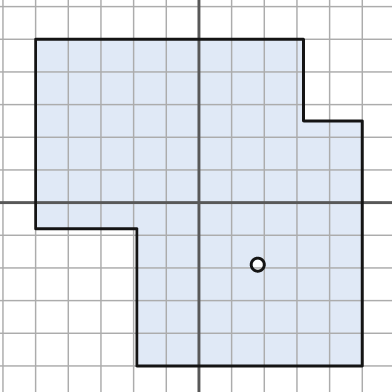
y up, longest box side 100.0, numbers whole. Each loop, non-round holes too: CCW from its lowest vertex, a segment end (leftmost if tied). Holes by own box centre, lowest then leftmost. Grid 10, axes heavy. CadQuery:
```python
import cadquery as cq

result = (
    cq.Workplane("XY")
    .moveTo(-19.0, -50.0)
    .lineTo(50.0, -50.0)
    .lineTo(50.0, 25.0)
    .lineTo(32.0, 25.0)
    .lineTo(32.0, 50.0)
    .lineTo(-50.0, 50.0)
    .lineTo(-50.0, -8.0)
    .lineTo(-19.0, -8.0)
    .close()
    .moveTo(18.0, -19.0)
    .circle(2.0)
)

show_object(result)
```